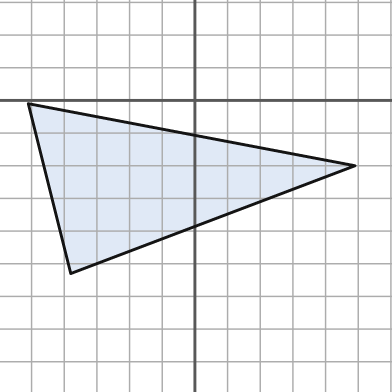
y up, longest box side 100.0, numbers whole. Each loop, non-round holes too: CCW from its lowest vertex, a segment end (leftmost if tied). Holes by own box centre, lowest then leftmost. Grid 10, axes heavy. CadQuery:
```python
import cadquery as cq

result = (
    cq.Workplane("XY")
    .moveTo(-38.0, -53.0)
    .lineTo(49.0, -20.0)
    .lineTo(-51.0, -1.0)
    .close()
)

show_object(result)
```